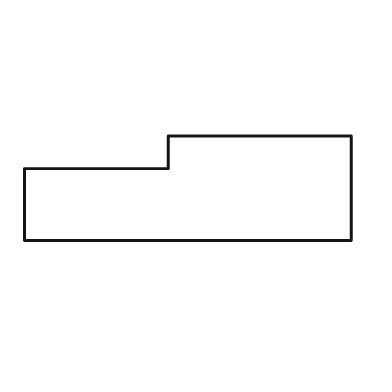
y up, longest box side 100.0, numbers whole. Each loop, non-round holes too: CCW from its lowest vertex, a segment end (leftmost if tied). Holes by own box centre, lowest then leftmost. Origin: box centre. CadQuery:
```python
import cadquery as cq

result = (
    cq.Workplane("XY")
    .moveTo(-50.0, -16.0)
    .lineTo(50.0, -16.0)
    .lineTo(50.0, 16.0)
    .lineTo(-6.0, 16.0)
    .lineTo(-6.0, 6.0)
    .lineTo(-50.0, 6.0)
    .close()
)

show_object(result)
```